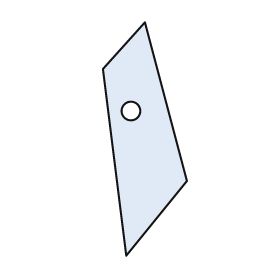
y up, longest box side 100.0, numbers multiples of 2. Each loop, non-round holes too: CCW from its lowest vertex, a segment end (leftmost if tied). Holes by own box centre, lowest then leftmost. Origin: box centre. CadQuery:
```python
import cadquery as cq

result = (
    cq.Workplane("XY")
    .moveTo(-8.0, -50.0)
    .lineTo(18.0, -18.0)
    .lineTo(0.0, 50.0)
    .lineTo(-18.0, 30.0)
    .close()
    .moveTo(-6.0, 12.0)
    .circle(4.0)
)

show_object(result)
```